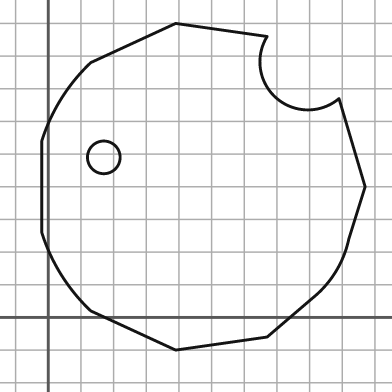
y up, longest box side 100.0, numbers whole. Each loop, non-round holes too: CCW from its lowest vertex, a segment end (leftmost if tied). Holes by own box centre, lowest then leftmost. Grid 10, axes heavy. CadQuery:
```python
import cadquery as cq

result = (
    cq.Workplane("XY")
    .moveTo(39.0, -10.0)
    .lineTo(67.0, -6.0)
    .lineTo(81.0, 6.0)
    .threePointArc((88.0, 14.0), (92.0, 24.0))
    .lineTo(97.0, 40.0)
    .lineTo(89.0, 67.0)
    .threePointArc((70.0, 67.0), (67.0, 86.0))
    .lineTo(39.0, 90.0)
    .lineTo(13.0, 78.0)
    .threePointArc((4.0, 67.0), (-2.0, 54.0))
    .lineTo(-2.0, 26.0)
    .threePointArc((4.0, 13.0), (13.0, 2.0))
    .close()
    .moveTo(17.0, 49.0)
    .circle(5.0)
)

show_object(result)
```